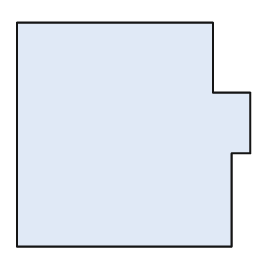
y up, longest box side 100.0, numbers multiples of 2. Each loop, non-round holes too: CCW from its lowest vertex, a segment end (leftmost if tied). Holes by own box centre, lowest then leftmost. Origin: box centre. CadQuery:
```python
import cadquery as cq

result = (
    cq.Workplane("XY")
    .moveTo(-50.0, -48.0)
    .lineTo(42.0, -48.0)
    .lineTo(42.0, -8.0)
    .lineTo(50.0, -8.0)
    .lineTo(50.0, 18.0)
    .lineTo(34.0, 18.0)
    .lineTo(34.0, 48.0)
    .lineTo(-50.0, 48.0)
    .close()
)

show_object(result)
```